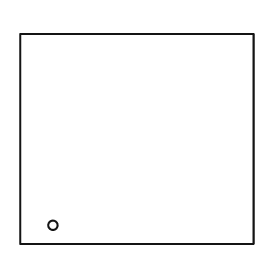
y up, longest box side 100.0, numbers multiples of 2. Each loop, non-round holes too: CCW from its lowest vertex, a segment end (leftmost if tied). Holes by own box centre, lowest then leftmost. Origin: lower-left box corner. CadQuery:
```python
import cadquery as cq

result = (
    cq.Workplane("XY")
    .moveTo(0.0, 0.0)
    .lineTo(100.0, 0.0)
    .lineTo(100.0, 90.0)
    .lineTo(0.0, 90.0)
    .close()
    .moveTo(14.0, 8.0)
    .circle(2.0)
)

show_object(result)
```